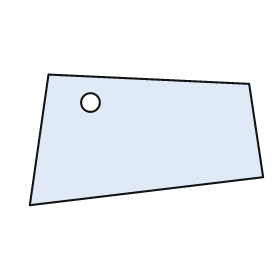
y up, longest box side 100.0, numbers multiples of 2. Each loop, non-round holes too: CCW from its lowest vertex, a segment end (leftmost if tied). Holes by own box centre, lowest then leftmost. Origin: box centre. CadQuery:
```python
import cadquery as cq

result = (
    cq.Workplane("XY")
    .moveTo(-50.0, -28.0)
    .lineTo(50.0, -16.0)
    .lineTo(44.0, 24.0)
    .lineTo(-42.0, 28.0)
    .close()
    .moveTo(-24.0, 16.0)
    .circle(4.0)
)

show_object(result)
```